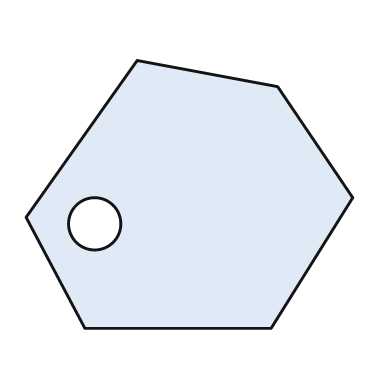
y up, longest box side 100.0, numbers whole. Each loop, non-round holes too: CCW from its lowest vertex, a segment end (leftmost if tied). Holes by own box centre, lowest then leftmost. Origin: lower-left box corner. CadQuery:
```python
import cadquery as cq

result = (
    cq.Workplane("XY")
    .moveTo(18.0, 0.0)
    .lineTo(75.0, 0.0)
    .lineTo(100.0, 40.0)
    .lineTo(77.0, 74.0)
    .lineTo(34.0, 82.0)
    .lineTo(0.0, 34.0)
    .close()
    .moveTo(21.0, 32.0)
    .circle(8.0)
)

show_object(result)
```